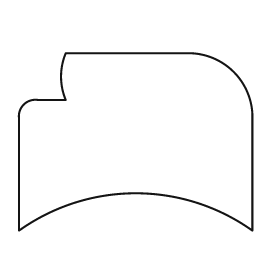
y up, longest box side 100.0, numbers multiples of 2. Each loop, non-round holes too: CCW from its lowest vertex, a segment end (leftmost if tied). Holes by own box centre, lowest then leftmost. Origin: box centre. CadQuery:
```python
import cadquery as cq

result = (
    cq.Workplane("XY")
    .moveTo(-50.0, -38.0)
    .threePointArc((0.0, -22.0), (50.0, -38.0))
    .lineTo(50.0, 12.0)
    .threePointArc((42.0, 30.0), (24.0, 38.0))
    .lineTo(-30.0, 38.0)
    .threePointArc((-32.0, 28.0), (-30.0, 18.0))
    .lineTo(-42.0, 18.0)
    .threePointArc((-48.0, 16.0), (-50.0, 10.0))
    .close()
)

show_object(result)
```